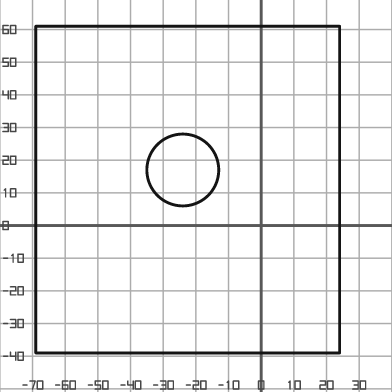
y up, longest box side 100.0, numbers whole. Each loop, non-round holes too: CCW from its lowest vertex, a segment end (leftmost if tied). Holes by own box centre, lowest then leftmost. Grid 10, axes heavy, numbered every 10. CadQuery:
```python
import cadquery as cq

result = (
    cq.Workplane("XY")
    .moveTo(-69.0, -39.0)
    .lineTo(24.0, -39.0)
    .lineTo(24.0, 61.0)
    .lineTo(-69.0, 61.0)
    .close()
    .moveTo(-24.0, 17.0)
    .circle(11.0)
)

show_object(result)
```